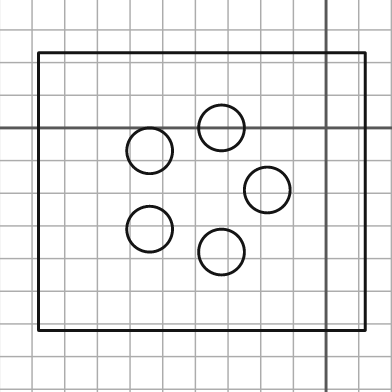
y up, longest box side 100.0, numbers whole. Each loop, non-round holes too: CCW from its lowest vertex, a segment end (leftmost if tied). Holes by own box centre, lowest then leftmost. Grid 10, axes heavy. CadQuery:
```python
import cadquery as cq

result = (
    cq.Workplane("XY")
    .moveTo(-88.0, -62.0)
    .lineTo(12.0, -62.0)
    .lineTo(12.0, 23.0)
    .lineTo(-88.0, 23.0)
    .close()
    .moveTo(-32.0, -38.0)
    .circle(7.0)
    .moveTo(-54.0, -31.0)
    .circle(7.0)
    .moveTo(-18.0, -19.0)
    .circle(7.0)
    .moveTo(-54.0, -7.0)
    .circle(7.0)
    .moveTo(-32.0, 0.0)
    .circle(7.0)
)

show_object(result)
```